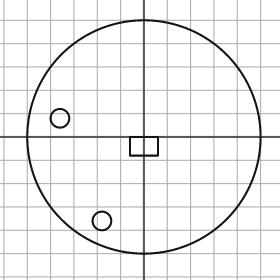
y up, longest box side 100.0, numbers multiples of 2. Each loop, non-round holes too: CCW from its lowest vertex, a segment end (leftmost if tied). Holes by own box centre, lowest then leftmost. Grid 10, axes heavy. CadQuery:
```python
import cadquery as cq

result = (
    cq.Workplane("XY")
    .moveTo(0.0, 0.0)
    .circle(50.0)
    .moveTo(-18.0, -36.0)
    .circle(4.0)
    .moveTo(-6.0, -8.0)
    .lineTo(6.0, -8.0)
    .lineTo(6.0, 0.0)
    .lineTo(-6.0, 0.0)
    .close()
    .moveTo(-36.0, 8.0)
    .circle(4.0)
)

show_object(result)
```